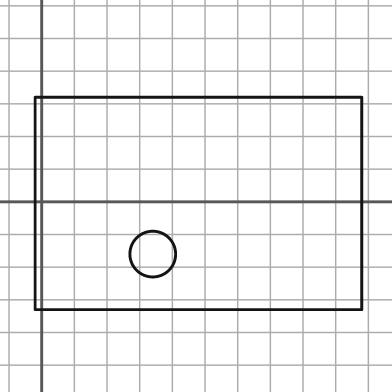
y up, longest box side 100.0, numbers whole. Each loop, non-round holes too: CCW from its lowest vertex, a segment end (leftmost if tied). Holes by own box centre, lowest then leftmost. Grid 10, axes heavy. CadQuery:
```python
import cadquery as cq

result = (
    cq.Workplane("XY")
    .moveTo(-2.0, -33.0)
    .lineTo(98.0, -33.0)
    .lineTo(98.0, 32.0)
    .lineTo(-2.0, 32.0)
    .close()
    .moveTo(34.0, -16.0)
    .circle(7.0)
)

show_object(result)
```